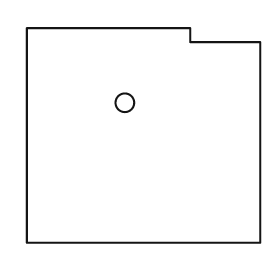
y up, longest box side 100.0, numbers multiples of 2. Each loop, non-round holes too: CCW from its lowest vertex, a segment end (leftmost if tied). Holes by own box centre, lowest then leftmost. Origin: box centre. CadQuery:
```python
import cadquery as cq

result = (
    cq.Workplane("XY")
    .moveTo(-50.0, -46.0)
    .lineTo(50.0, -46.0)
    .lineTo(50.0, 40.0)
    .lineTo(20.0, 40.0)
    .lineTo(20.0, 46.0)
    .lineTo(-50.0, 46.0)
    .close()
    .moveTo(-8.0, 14.0)
    .circle(4.0)
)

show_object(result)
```